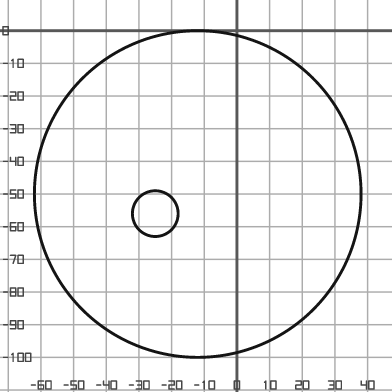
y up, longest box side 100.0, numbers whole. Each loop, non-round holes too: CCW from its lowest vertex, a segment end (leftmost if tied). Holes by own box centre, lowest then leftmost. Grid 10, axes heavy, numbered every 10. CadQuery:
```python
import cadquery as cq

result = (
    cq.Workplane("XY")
    .moveTo(-12.0, -50.0)
    .circle(50.0)
    .moveTo(-25.0, -56.0)
    .circle(7.0)
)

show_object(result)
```